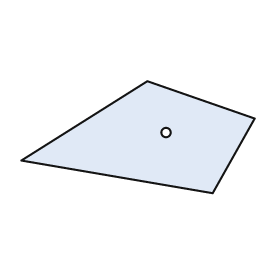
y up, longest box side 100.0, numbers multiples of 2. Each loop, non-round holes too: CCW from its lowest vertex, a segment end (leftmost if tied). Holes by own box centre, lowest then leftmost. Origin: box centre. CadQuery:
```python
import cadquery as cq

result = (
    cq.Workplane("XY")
    .moveTo(32.0, -24.0)
    .lineTo(50.0, 8.0)
    .lineTo(4.0, 24.0)
    .lineTo(-50.0, -10.0)
    .close()
    .moveTo(12.0, 2.0)
    .circle(2.0)
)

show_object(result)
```